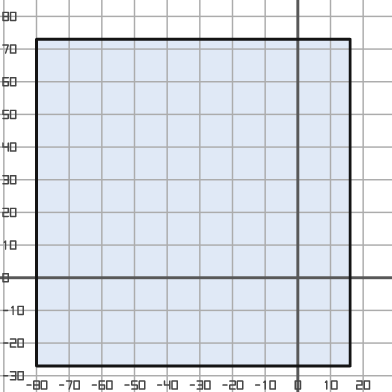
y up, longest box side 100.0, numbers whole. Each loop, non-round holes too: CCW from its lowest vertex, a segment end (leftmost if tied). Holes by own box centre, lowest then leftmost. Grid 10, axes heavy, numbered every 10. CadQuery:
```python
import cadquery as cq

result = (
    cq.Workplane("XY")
    .moveTo(-80.0, -27.0)
    .lineTo(16.0, -27.0)
    .lineTo(16.0, 73.0)
    .lineTo(-80.0, 73.0)
    .close()
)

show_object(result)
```